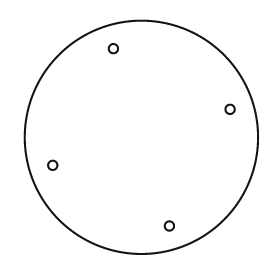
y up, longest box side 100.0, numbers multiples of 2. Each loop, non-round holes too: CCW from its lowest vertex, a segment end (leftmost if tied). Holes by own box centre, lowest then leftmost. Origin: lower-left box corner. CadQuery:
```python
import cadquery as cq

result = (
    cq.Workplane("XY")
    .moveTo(50.0, 50.0)
    .circle(50.0)
    .moveTo(62.0, 12.0)
    .circle(2.0)
    .moveTo(12.0, 38.0)
    .circle(2.0)
    .moveTo(88.0, 62.0)
    .circle(2.0)
    .moveTo(38.0, 88.0)
    .circle(2.0)
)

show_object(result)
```